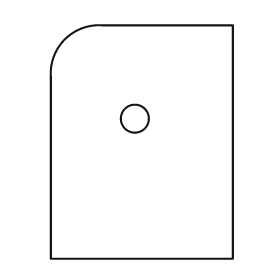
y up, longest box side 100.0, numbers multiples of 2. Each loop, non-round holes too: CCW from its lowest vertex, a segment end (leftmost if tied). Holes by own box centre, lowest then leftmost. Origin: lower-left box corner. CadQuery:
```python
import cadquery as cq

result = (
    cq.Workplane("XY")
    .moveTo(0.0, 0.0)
    .lineTo(78.0, 0.0)
    .lineTo(78.0, 100.0)
    .lineTo(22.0, 100.0)
    .threePointArc((6.0, 94.0), (0.0, 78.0))
    .close()
    .moveTo(36.0, 60.0)
    .circle(6.0)
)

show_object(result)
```